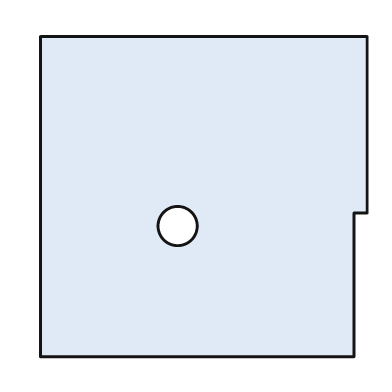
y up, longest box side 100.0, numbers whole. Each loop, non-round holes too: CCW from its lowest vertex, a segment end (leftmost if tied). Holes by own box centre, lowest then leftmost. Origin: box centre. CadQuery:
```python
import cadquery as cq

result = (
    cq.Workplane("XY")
    .moveTo(-50.0, -49.0)
    .lineTo(46.0, -49.0)
    .lineTo(46.0, -5.0)
    .lineTo(50.0, -5.0)
    .lineTo(50.0, 49.0)
    .lineTo(-50.0, 49.0)
    .close()
    .moveTo(-8.0, -9.0)
    .circle(6.0)
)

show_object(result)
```